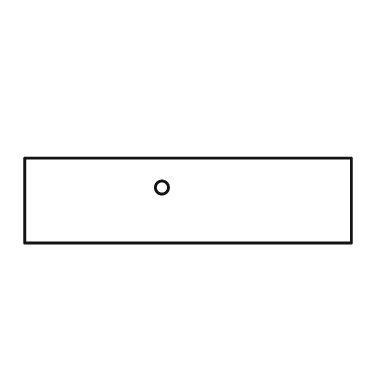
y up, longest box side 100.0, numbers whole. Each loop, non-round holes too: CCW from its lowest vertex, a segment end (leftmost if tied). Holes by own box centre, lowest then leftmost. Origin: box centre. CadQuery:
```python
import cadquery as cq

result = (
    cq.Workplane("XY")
    .moveTo(-50.0, -13.0)
    .lineTo(50.0, -13.0)
    .lineTo(50.0, 13.0)
    .lineTo(-50.0, 13.0)
    .close()
    .moveTo(-8.0, 4.0)
    .circle(2.0)
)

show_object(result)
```